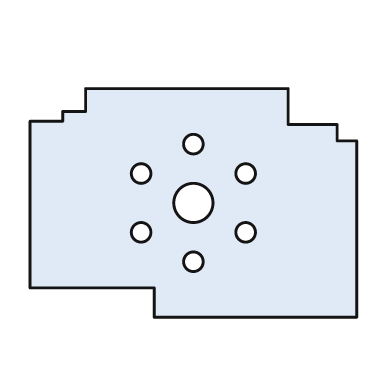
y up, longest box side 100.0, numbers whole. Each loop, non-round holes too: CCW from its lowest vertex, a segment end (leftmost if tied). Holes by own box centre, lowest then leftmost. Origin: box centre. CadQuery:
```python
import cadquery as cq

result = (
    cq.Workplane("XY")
    .moveTo(-12.0, -35.0)
    .lineTo(50.0, -35.0)
    .lineTo(50.0, 19.0)
    .lineTo(44.0, 19.0)
    .lineTo(44.0, 24.0)
    .lineTo(29.0, 24.0)
    .lineTo(29.0, 35.0)
    .lineTo(-33.0, 35.0)
    .lineTo(-33.0, 28.0)
    .lineTo(-40.0, 28.0)
    .lineTo(-40.0, 25.0)
    .lineTo(-50.0, 25.0)
    .lineTo(-50.0, -26.0)
    .lineTo(-12.0, -26.0)
    .close()
    .moveTo(0.0, -18.0)
    .circle(3.0)
    .moveTo(-16.0, -9.0)
    .circle(3.0)
    .moveTo(16.0, -9.0)
    .circle(3.0)
    .moveTo(0.0, 0.0)
    .circle(6.0)
    .moveTo(-16.0, 9.0)
    .circle(3.0)
    .moveTo(16.0, 9.0)
    .circle(3.0)
    .moveTo(0.0, 18.0)
    .circle(3.0)
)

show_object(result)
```